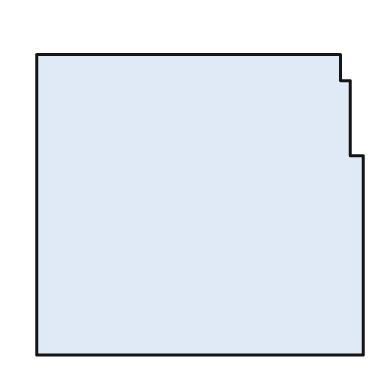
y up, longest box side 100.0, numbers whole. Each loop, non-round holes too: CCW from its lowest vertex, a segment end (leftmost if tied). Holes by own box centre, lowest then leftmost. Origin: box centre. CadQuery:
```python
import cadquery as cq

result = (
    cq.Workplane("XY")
    .moveTo(-50.0, -46.0)
    .lineTo(50.0, -46.0)
    .lineTo(50.0, 15.0)
    .lineTo(46.0, 15.0)
    .lineTo(46.0, 38.0)
    .lineTo(43.0, 38.0)
    .lineTo(43.0, 46.0)
    .lineTo(-50.0, 46.0)
    .close()
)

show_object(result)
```